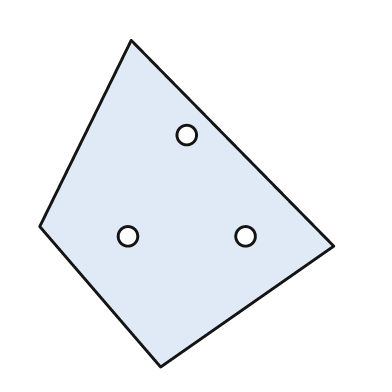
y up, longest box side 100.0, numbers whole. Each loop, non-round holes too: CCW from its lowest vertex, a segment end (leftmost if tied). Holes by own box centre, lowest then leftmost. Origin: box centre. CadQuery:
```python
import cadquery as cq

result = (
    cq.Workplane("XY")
    .moveTo(-8.0, -50.0)
    .lineTo(45.0, -13.0)
    .lineTo(-17.0, 50.0)
    .lineTo(-45.0, -7.0)
    .close()
    .moveTo(-18.0, -10.0)
    .circle(3.0)
    .moveTo(18.0, -10.0)
    .circle(3.0)
    .moveTo(0.0, 21.0)
    .circle(3.0)
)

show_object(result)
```